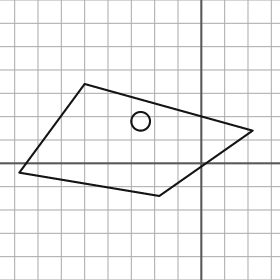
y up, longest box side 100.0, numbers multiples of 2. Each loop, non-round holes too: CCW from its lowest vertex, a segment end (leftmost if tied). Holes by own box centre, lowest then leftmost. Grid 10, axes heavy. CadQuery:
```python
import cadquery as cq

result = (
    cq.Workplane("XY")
    .moveTo(-18.0, -14.0)
    .lineTo(22.0, 14.0)
    .lineTo(-50.0, 34.0)
    .lineTo(-78.0, -4.0)
    .close()
    .moveTo(-26.0, 18.0)
    .circle(4.0)
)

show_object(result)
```